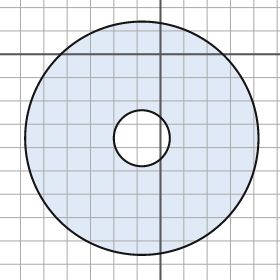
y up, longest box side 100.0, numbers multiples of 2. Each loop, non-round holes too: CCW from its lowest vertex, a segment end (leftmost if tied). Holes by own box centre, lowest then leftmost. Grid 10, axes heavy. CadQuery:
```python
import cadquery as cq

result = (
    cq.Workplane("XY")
    .moveTo(-8.0, -36.0)
    .circle(50.0)
    .moveTo(-8.0, -36.0)
    .circle(12.0)
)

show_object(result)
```